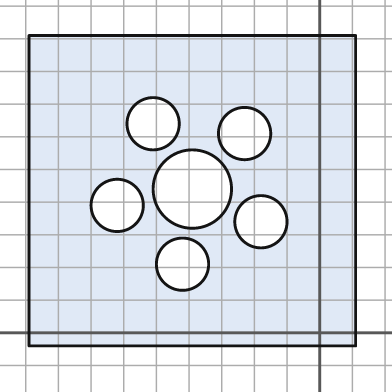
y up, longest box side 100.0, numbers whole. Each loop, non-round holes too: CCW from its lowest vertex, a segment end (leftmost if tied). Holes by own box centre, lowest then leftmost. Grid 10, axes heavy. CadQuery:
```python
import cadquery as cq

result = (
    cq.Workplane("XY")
    .moveTo(-89.0, -4.0)
    .lineTo(11.0, -4.0)
    .lineTo(11.0, 91.0)
    .lineTo(-89.0, 91.0)
    .close()
    .moveTo(-42.0, 21.0)
    .circle(8.0)
    .moveTo(-18.0, 34.0)
    .circle(8.0)
    .moveTo(-62.0, 39.0)
    .circle(8.0)
    .moveTo(-39.0, 44.0)
    .circle(12.0)
    .moveTo(-23.0, 61.0)
    .circle(8.0)
    .moveTo(-51.0, 64.0)
    .circle(8.0)
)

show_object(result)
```